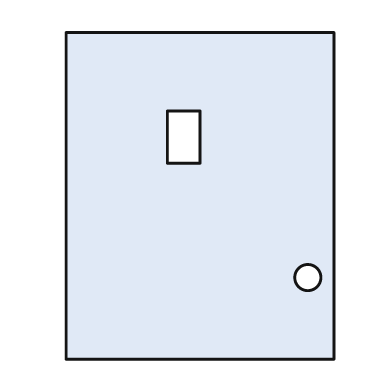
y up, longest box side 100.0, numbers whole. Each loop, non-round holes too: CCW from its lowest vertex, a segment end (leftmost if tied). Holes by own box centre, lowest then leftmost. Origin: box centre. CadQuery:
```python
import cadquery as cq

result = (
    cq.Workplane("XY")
    .moveTo(-41.0, -50.0)
    .lineTo(41.0, -50.0)
    .lineTo(41.0, 50.0)
    .lineTo(-41.0, 50.0)
    .close()
    .moveTo(33.0, -25.0)
    .circle(4.0)
    .moveTo(-10.0, 10.0)
    .lineTo(0.0, 10.0)
    .lineTo(0.0, 26.0)
    .lineTo(-10.0, 26.0)
    .close()
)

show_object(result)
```